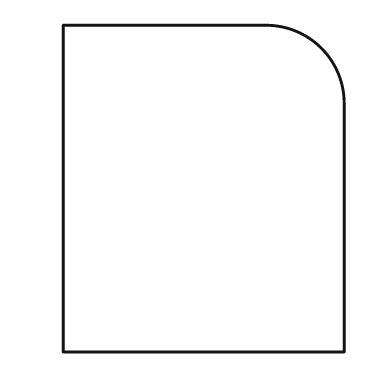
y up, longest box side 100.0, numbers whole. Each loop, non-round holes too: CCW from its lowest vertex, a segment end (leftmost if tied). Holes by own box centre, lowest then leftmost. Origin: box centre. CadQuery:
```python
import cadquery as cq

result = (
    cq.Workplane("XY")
    .moveTo(-43.0, -50.0)
    .lineTo(43.0, -50.0)
    .lineTo(43.0, 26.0)
    .threePointArc((36.0, 43.0), (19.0, 50.0))
    .lineTo(-43.0, 50.0)
    .close()
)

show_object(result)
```